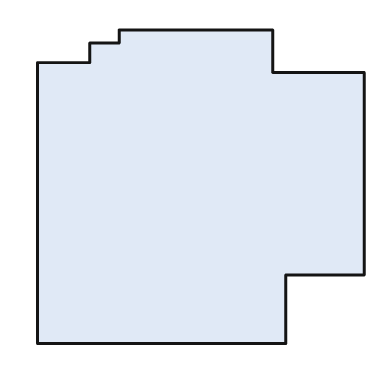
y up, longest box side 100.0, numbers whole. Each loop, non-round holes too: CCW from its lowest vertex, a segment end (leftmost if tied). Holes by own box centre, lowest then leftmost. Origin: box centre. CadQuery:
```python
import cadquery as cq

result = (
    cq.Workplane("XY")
    .moveTo(-50.0, -48.0)
    .lineTo(26.0, -48.0)
    .lineTo(26.0, -27.0)
    .lineTo(50.0, -27.0)
    .lineTo(50.0, 35.0)
    .lineTo(22.0, 35.0)
    .lineTo(22.0, 48.0)
    .lineTo(-25.0, 48.0)
    .lineTo(-25.0, 44.0)
    .lineTo(-34.0, 44.0)
    .lineTo(-34.0, 38.0)
    .lineTo(-50.0, 38.0)
    .close()
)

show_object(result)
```